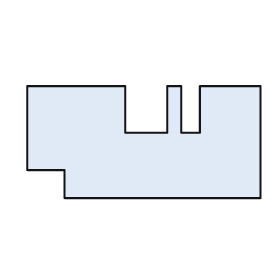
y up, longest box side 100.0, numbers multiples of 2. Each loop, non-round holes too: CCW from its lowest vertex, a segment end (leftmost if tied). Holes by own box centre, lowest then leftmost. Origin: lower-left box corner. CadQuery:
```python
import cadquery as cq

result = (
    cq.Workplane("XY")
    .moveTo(16.0, 0.0)
    .lineTo(100.0, 0.0)
    .lineTo(100.0, 48.0)
    .lineTo(74.0, 48.0)
    .lineTo(74.0, 28.0)
    .lineTo(66.0, 28.0)
    .lineTo(66.0, 48.0)
    .lineTo(60.0, 48.0)
    .lineTo(60.0, 28.0)
    .lineTo(42.0, 28.0)
    .lineTo(42.0, 48.0)
    .lineTo(0.0, 48.0)
    .lineTo(0.0, 12.0)
    .lineTo(16.0, 12.0)
    .close()
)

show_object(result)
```